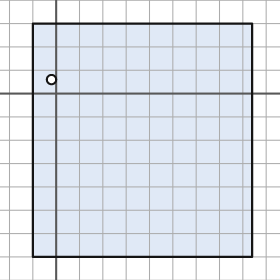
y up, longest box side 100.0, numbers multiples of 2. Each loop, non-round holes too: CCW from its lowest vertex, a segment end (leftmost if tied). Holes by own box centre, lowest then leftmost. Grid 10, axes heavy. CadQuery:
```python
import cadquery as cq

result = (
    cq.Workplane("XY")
    .moveTo(-10.0, -70.0)
    .lineTo(84.0, -70.0)
    .lineTo(84.0, 30.0)
    .lineTo(-10.0, 30.0)
    .close()
    .moveTo(-2.0, 6.0)
    .circle(2.0)
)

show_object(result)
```